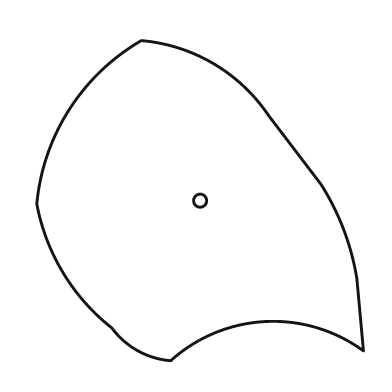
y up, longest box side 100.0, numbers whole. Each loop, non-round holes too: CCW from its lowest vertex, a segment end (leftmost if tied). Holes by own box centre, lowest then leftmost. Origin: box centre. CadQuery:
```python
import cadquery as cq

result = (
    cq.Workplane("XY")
    .moveTo(-9.0, -49.0)
    .threePointArc((20.0, -37.0), (50.0, -46.0))
    .lineTo(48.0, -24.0)
    .threePointArc((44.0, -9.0), (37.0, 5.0))
    .lineTo(21.0, 26.0)
    .threePointArc((4.0, 42.0), (-18.0, 49.0))
    .threePointArc((-40.0, 28.0), (-50.0, -1.0))
    .threePointArc((-42.0, -22.0), (-27.0, -39.0))
    .threePointArc((-19.0, -46.0), (-9.0, -49.0))
    .close()
    .moveTo(0.0, 0.0)
    .circle(2.0)
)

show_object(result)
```